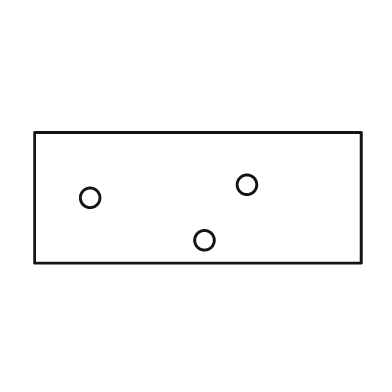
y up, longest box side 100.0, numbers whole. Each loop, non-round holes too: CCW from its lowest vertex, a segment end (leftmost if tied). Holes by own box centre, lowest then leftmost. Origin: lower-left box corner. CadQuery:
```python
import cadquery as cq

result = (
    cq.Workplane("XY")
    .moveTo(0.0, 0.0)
    .lineTo(100.0, 0.0)
    .lineTo(100.0, 40.0)
    .lineTo(0.0, 40.0)
    .close()
    .moveTo(52.0, 7.0)
    .circle(3.0)
    .moveTo(17.0, 20.0)
    .circle(3.0)
    .moveTo(65.0, 24.0)
    .circle(3.0)
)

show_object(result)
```